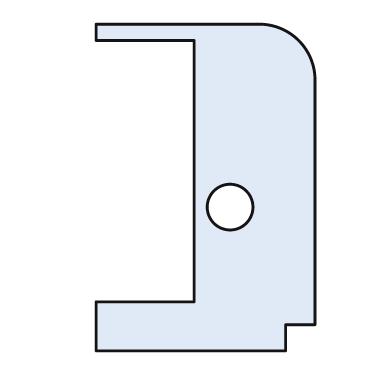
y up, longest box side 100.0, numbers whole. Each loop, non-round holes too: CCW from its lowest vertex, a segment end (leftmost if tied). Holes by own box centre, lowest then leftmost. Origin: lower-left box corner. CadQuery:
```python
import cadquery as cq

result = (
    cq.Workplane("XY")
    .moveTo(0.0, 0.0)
    .lineTo(58.0, 0.0)
    .lineTo(58.0, 8.0)
    .lineTo(67.0, 8.0)
    .lineTo(67.0, 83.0)
    .threePointArc((62.0, 95.0), (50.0, 100.0))
    .lineTo(0.0, 100.0)
    .lineTo(0.0, 95.0)
    .lineTo(30.0, 95.0)
    .lineTo(30.0, 15.0)
    .lineTo(0.0, 15.0)
    .close()
    .moveTo(41.0, 44.0)
    .circle(7.0)
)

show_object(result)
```